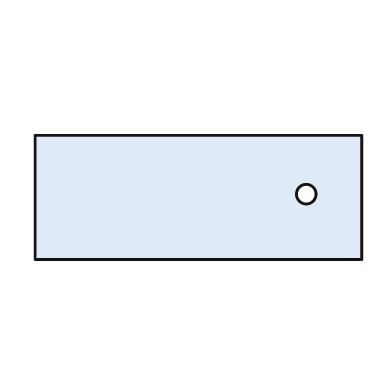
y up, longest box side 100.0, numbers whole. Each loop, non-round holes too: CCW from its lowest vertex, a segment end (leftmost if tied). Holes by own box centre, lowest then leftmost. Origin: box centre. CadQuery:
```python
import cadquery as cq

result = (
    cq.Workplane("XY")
    .moveTo(-50.0, -19.0)
    .lineTo(50.0, -19.0)
    .lineTo(50.0, 19.0)
    .lineTo(-50.0, 19.0)
    .close()
    .moveTo(33.0, 1.0)
    .circle(3.0)
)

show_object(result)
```